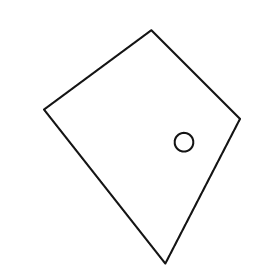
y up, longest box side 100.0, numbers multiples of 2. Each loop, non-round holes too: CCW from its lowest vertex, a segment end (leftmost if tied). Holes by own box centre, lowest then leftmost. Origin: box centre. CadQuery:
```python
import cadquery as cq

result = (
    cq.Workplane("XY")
    .moveTo(10.0, -50.0)
    .lineTo(42.0, 12.0)
    .lineTo(4.0, 50.0)
    .lineTo(-42.0, 16.0)
    .close()
    .moveTo(18.0, 2.0)
    .circle(4.0)
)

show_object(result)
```